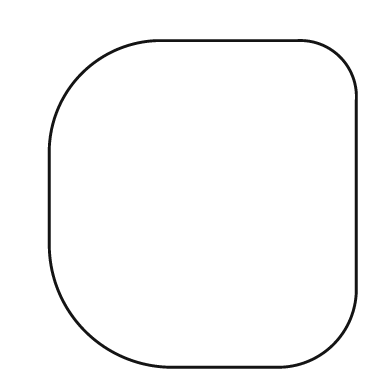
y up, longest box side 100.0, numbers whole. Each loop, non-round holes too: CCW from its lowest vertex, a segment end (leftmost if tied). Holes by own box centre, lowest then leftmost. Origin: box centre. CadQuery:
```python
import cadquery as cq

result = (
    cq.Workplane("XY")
    .moveTo(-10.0, -50.0)
    .lineTo(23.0, -50.0)
    .threePointArc((40.0, -43.0), (47.0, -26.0))
    .lineTo(47.0, 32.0)
    .threePointArc((42.0, 45.0), (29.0, 50.0))
    .lineTo(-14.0, 50.0)
    .threePointArc((-37.0, 40.0), (-47.0, 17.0))
    .lineTo(-47.0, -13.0)
    .threePointArc((-36.0, -39.0), (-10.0, -50.0))
    .close()
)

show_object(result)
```